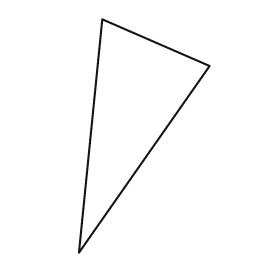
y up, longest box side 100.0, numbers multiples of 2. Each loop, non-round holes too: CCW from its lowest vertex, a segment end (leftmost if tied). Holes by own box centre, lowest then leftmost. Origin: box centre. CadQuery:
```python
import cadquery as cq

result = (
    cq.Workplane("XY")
    .moveTo(-28.0, -50.0)
    .lineTo(28.0, 30.0)
    .lineTo(-18.0, 50.0)
    .close()
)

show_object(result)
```